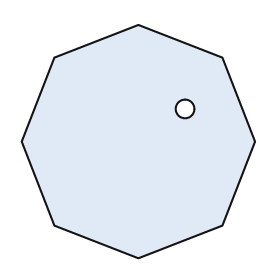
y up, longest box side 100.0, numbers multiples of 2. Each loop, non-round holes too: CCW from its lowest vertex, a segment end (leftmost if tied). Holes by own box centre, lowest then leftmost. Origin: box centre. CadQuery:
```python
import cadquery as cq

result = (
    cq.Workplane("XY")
    .moveTo(0.0, -50.0)
    .lineTo(36.0, -36.0)
    .lineTo(50.0, 0.0)
    .lineTo(36.0, 36.0)
    .lineTo(0.0, 50.0)
    .lineTo(-36.0, 36.0)
    .lineTo(-50.0, 0.0)
    .lineTo(-36.0, -36.0)
    .close()
    .moveTo(20.0, 14.0)
    .circle(4.0)
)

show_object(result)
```